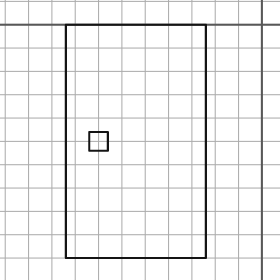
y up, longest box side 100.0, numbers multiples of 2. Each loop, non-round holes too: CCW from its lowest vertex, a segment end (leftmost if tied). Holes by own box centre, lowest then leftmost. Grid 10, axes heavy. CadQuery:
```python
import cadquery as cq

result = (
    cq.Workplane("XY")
    .moveTo(-84.0, -100.0)
    .lineTo(-24.0, -100.0)
    .lineTo(-24.0, 0.0)
    .lineTo(-84.0, 0.0)
    .close()
    .moveTo(-74.0, -54.0)
    .lineTo(-66.0, -54.0)
    .lineTo(-66.0, -46.0)
    .lineTo(-74.0, -46.0)
    .close()
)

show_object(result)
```